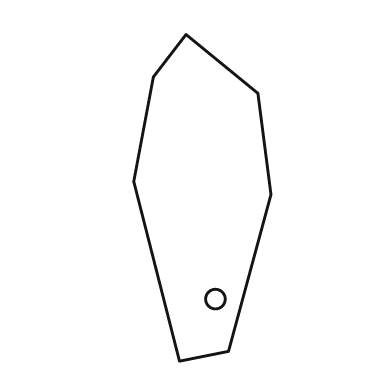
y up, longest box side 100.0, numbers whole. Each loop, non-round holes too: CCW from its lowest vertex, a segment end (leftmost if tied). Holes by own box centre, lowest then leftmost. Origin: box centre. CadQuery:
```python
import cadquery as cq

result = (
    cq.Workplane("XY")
    .moveTo(-7.0, -50.0)
    .lineTo(8.0, -47.0)
    .lineTo(21.0, 1.0)
    .lineTo(17.0, 32.0)
    .lineTo(-5.0, 50.0)
    .lineTo(-15.0, 37.0)
    .lineTo(-21.0, 5.0)
    .close()
    .moveTo(4.0, -31.0)
    .circle(3.0)
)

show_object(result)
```